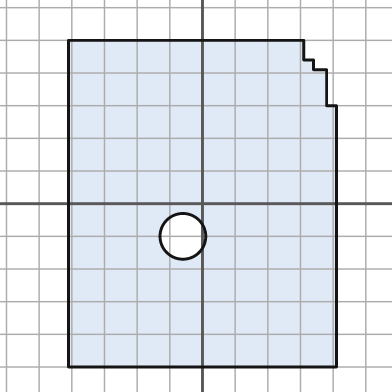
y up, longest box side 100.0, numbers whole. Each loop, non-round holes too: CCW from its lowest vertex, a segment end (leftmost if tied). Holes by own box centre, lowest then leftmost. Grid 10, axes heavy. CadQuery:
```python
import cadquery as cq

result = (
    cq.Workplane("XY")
    .moveTo(-41.0, -50.0)
    .lineTo(41.0, -50.0)
    .lineTo(41.0, 30.0)
    .lineTo(38.0, 30.0)
    .lineTo(38.0, 41.0)
    .lineTo(34.0, 41.0)
    .lineTo(34.0, 44.0)
    .lineTo(31.0, 44.0)
    .lineTo(31.0, 50.0)
    .lineTo(-41.0, 50.0)
    .close()
    .moveTo(-6.0, -10.0)
    .circle(7.0)
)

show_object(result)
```